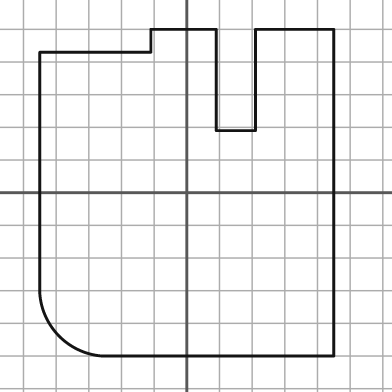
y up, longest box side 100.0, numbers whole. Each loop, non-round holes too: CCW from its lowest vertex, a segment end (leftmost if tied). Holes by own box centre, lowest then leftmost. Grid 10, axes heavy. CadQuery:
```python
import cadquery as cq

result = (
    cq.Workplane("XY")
    .moveTo(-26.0, -50.0)
    .lineTo(45.0, -50.0)
    .lineTo(45.0, 50.0)
    .lineTo(21.0, 50.0)
    .lineTo(21.0, 19.0)
    .lineTo(9.0, 19.0)
    .lineTo(9.0, 50.0)
    .lineTo(-11.0, 50.0)
    .lineTo(-11.0, 43.0)
    .lineTo(-45.0, 43.0)
    .lineTo(-45.0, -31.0)
    .threePointArc((-39.0, -44.0), (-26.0, -50.0))
    .close()
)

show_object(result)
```